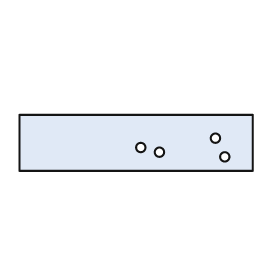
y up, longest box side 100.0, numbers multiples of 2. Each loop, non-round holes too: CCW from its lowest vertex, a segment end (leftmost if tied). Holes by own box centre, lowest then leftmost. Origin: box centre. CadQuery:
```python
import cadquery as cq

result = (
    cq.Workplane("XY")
    .moveTo(-50.0, -12.0)
    .lineTo(50.0, -12.0)
    .lineTo(50.0, 12.0)
    .lineTo(-50.0, 12.0)
    .close()
    .moveTo(38.0, -6.0)
    .circle(2.0)
    .moveTo(10.0, -4.0)
    .circle(2.0)
    .moveTo(2.0, -2.0)
    .circle(2.0)
    .moveTo(34.0, 2.0)
    .circle(2.0)
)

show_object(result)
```